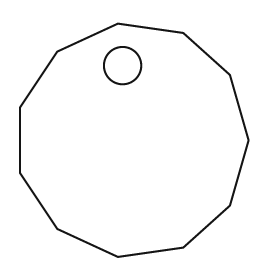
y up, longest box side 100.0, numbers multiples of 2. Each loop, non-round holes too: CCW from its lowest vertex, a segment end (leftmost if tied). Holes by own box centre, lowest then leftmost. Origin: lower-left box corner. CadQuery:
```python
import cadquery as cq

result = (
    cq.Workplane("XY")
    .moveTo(42.0, 0.0)
    .lineTo(70.0, 4.0)
    .lineTo(90.0, 22.0)
    .lineTo(98.0, 50.0)
    .lineTo(90.0, 78.0)
    .lineTo(70.0, 96.0)
    .lineTo(42.0, 100.0)
    .lineTo(16.0, 88.0)
    .lineTo(0.0, 64.0)
    .lineTo(0.0, 36.0)
    .lineTo(16.0, 12.0)
    .close()
    .moveTo(44.0, 82.0)
    .circle(8.0)
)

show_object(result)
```